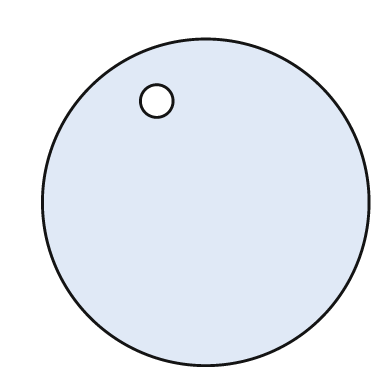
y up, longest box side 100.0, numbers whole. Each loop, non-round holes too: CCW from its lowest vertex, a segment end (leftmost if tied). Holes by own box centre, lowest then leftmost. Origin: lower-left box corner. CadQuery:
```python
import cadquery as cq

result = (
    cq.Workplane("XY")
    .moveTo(50.0, 50.0)
    .circle(50.0)
    .moveTo(35.0, 81.0)
    .circle(5.0)
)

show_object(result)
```